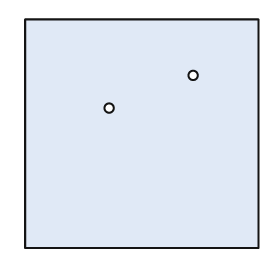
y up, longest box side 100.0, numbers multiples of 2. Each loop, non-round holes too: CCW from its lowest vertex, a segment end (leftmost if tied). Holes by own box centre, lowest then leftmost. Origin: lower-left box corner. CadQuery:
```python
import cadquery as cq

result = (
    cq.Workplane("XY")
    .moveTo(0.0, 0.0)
    .lineTo(100.0, 0.0)
    .lineTo(100.0, 98.0)
    .lineTo(0.0, 98.0)
    .close()
    .moveTo(36.0, 60.0)
    .circle(2.0)
    .moveTo(72.0, 74.0)
    .circle(2.0)
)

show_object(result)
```